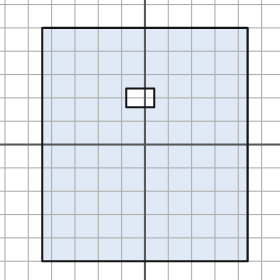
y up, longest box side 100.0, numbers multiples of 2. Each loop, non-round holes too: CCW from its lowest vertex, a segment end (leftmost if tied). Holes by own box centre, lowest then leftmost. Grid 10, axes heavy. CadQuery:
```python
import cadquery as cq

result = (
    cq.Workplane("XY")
    .moveTo(-44.0, -50.0)
    .lineTo(44.0, -50.0)
    .lineTo(44.0, 50.0)
    .lineTo(-44.0, 50.0)
    .close()
    .moveTo(-8.0, 16.0)
    .lineTo(4.0, 16.0)
    .lineTo(4.0, 24.0)
    .lineTo(-8.0, 24.0)
    .close()
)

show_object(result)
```